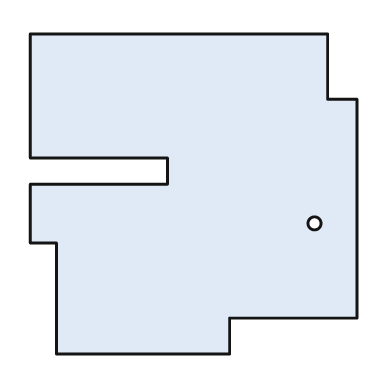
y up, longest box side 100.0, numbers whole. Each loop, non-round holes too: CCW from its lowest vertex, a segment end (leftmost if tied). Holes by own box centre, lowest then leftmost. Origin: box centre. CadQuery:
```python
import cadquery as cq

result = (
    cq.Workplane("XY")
    .moveTo(-42.0, -49.0)
    .lineTo(11.0, -49.0)
    .lineTo(11.0, -38.0)
    .lineTo(50.0, -38.0)
    .lineTo(50.0, 29.0)
    .lineTo(41.0, 29.0)
    .lineTo(41.0, 49.0)
    .lineTo(-50.0, 49.0)
    .lineTo(-50.0, 11.0)
    .lineTo(-8.0, 11.0)
    .lineTo(-8.0, 3.0)
    .lineTo(-50.0, 3.0)
    .lineTo(-50.0, -15.0)
    .lineTo(-42.0, -15.0)
    .close()
    .moveTo(37.0, -9.0)
    .circle(2.0)
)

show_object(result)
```